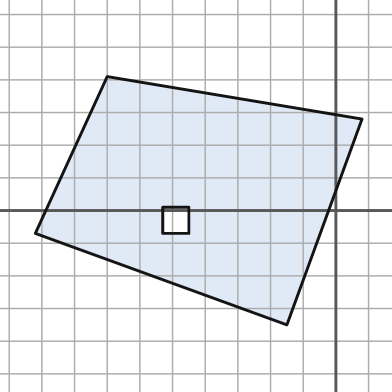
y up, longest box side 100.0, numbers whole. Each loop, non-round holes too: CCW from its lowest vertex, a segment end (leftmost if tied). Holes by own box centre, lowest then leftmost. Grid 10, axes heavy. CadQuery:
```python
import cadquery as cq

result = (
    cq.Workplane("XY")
    .moveTo(-15.0, -35.0)
    .lineTo(8.0, 28.0)
    .lineTo(-70.0, 41.0)
    .lineTo(-92.0, -7.0)
    .close()
    .moveTo(-53.0, -7.0)
    .lineTo(-45.0, -7.0)
    .lineTo(-45.0, 1.0)
    .lineTo(-53.0, 1.0)
    .close()
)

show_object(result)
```